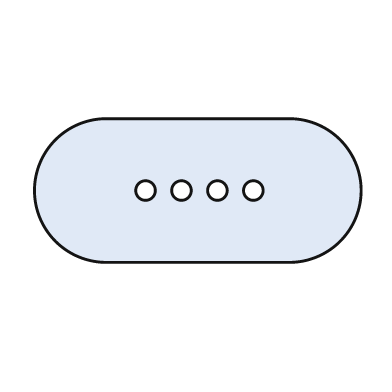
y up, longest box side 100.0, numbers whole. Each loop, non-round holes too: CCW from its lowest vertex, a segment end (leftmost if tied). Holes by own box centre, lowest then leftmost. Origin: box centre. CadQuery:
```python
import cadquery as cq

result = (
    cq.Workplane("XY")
    .moveTo(-28.0, -22.0)
    .lineTo(28.0, -22.0)
    .threePointArc((50.0, 0.0), (28.0, 22.0))
    .lineTo(-28.0, 22.0)
    .threePointArc((-50.0, 0.0), (-28.0, -22.0))
    .close()
    .moveTo(-16.0, 0.0)
    .circle(3.0)
    .moveTo(-5.0, 0.0)
    .circle(3.0)
    .moveTo(6.0, 0.0)
    .circle(3.0)
    .moveTo(17.0, 0.0)
    .circle(3.0)
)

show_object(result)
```